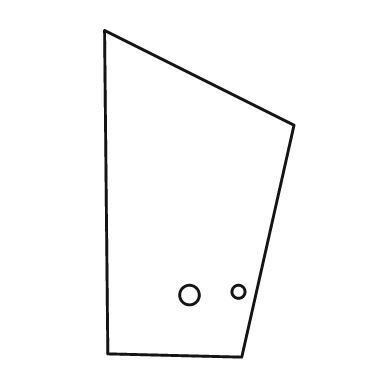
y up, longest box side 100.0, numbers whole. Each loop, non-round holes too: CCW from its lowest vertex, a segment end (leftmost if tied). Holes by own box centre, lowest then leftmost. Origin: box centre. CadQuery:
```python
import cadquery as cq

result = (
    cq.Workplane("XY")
    .moveTo(13.0, -50.0)
    .lineTo(29.0, 21.0)
    .lineTo(-29.0, 50.0)
    .lineTo(-28.0, -49.0)
    .close()
    .moveTo(-3.0, -31.0)
    .circle(3.0)
    .moveTo(12.0, -30.0)
    .circle(2.0)
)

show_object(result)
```